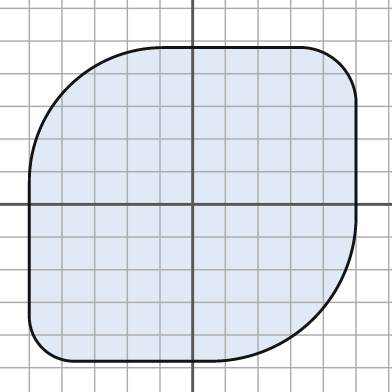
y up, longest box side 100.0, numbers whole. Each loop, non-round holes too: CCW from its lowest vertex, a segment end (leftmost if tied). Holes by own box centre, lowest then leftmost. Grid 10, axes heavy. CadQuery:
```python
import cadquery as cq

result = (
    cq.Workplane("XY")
    .moveTo(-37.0, -48.0)
    .lineTo(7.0, -48.0)
    .threePointArc((37.0, -35.0), (50.0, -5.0))
    .lineTo(50.0, 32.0)
    .threePointArc((45.0, 43.0), (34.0, 48.0))
    .lineTo(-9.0, 48.0)
    .threePointArc((-38.0, 36.0), (-50.0, 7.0))
    .lineTo(-50.0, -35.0)
    .threePointArc((-46.0, -44.0), (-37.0, -48.0))
    .close()
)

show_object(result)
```